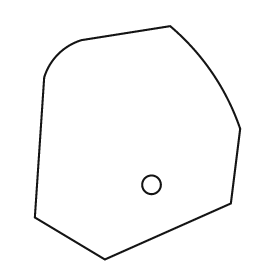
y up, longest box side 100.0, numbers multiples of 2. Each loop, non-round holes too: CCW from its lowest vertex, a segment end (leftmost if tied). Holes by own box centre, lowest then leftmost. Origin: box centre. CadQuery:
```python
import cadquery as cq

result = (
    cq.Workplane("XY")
    .moveTo(-14.0, -50.0)
    .lineTo(40.0, -26.0)
    .lineTo(44.0, 6.0)
    .threePointArc((32.0, 30.0), (14.0, 50.0))
    .lineTo(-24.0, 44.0)
    .threePointArc((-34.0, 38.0), (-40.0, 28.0))
    .lineTo(-44.0, -32.0)
    .close()
    .moveTo(6.0, -18.0)
    .circle(4.0)
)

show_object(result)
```